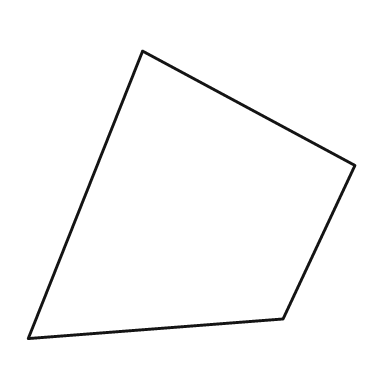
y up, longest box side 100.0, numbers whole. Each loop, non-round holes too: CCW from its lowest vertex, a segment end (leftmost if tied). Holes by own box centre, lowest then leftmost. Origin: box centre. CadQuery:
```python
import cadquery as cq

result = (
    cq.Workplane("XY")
    .moveTo(-50.0, -44.0)
    .lineTo(28.0, -38.0)
    .lineTo(50.0, 9.0)
    .lineTo(-15.0, 44.0)
    .close()
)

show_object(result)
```